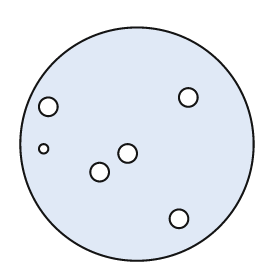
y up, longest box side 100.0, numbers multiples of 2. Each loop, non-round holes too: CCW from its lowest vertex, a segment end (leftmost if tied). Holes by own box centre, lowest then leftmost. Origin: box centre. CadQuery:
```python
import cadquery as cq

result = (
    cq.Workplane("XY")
    .moveTo(0.0, 0.0)
    .circle(50.0)
    .moveTo(18.0, -32.0)
    .circle(4.0)
    .moveTo(-16.0, -12.0)
    .circle(4.0)
    .moveTo(-4.0, -4.0)
    .circle(4.0)
    .moveTo(-40.0, -2.0)
    .circle(2.0)
    .moveTo(-38.0, 16.0)
    .circle(4.0)
    .moveTo(22.0, 20.0)
    .circle(4.0)
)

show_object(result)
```